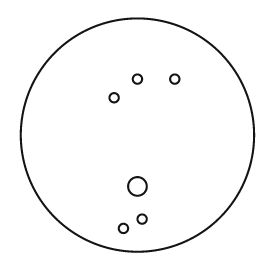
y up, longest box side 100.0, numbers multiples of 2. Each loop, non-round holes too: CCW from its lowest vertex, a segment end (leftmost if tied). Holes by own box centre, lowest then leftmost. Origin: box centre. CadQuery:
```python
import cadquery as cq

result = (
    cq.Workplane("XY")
    .moveTo(0.0, 0.0)
    .circle(50.0)
    .moveTo(-6.0, -40.0)
    .circle(2.0)
    .moveTo(2.0, -36.0)
    .circle(2.0)
    .moveTo(0.0, -22.0)
    .circle(4.0)
    .moveTo(-10.0, 16.0)
    .circle(2.0)
    .moveTo(0.0, 24.0)
    .circle(2.0)
    .moveTo(16.0, 24.0)
    .circle(2.0)
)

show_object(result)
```